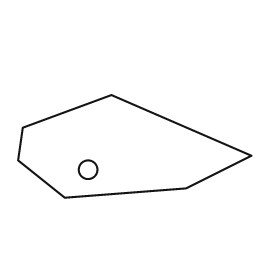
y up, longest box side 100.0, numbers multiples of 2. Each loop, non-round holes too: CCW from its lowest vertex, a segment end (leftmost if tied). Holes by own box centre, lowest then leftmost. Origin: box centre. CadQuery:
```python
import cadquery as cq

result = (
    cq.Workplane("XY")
    .moveTo(-30.0, -22.0)
    .lineTo(22.0, -18.0)
    .lineTo(50.0, -4.0)
    .lineTo(-10.0, 22.0)
    .lineTo(-48.0, 8.0)
    .lineTo(-50.0, -6.0)
    .close()
    .moveTo(-20.0, -10.0)
    .circle(4.0)
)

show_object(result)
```